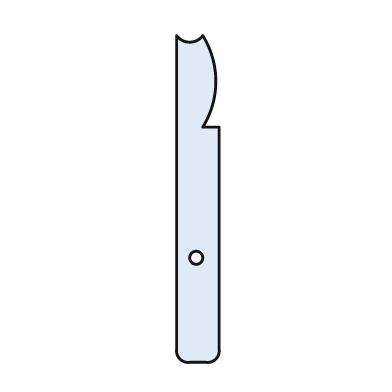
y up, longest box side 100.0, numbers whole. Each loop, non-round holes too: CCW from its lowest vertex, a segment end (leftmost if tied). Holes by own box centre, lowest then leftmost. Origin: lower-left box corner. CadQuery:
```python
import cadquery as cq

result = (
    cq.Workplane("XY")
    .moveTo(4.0, 0.0)
    .lineTo(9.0, 0.0)
    .threePointArc((12.0, 1.0), (13.0, 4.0))
    .lineTo(13.0, 72.0)
    .lineTo(8.0, 72.0)
    .threePointArc((12.0, 86.0), (8.0, 100.0))
    .threePointArc((4.0, 98.0), (0.0, 100.0))
    .lineTo(0.0, 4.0)
    .threePointArc((1.0, 1.0), (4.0, 0.0))
    .close()
    .moveTo(6.0, 32.0)
    .circle(2.0)
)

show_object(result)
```